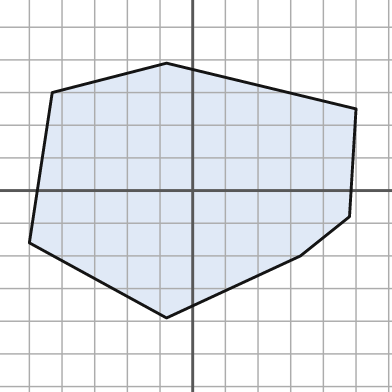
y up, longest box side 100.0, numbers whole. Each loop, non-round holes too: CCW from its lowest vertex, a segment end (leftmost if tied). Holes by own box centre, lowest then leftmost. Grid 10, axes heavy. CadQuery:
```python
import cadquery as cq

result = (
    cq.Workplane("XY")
    .moveTo(-8.0, -39.0)
    .lineTo(33.0, -20.0)
    .lineTo(48.0, -8.0)
    .lineTo(50.0, 25.0)
    .lineTo(-8.0, 39.0)
    .lineTo(-43.0, 30.0)
    .lineTo(-50.0, -16.0)
    .close()
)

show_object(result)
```